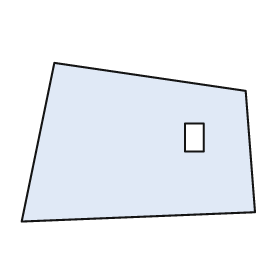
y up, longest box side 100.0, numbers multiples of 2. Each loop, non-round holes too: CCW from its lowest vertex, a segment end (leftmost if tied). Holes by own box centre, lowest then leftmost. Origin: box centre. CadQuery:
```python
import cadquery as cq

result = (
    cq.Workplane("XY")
    .moveTo(-50.0, -34.0)
    .lineTo(50.0, -30.0)
    .lineTo(46.0, 22.0)
    .lineTo(-36.0, 34.0)
    .close()
    .moveTo(20.0, -4.0)
    .lineTo(28.0, -4.0)
    .lineTo(28.0, 8.0)
    .lineTo(20.0, 8.0)
    .close()
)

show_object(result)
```